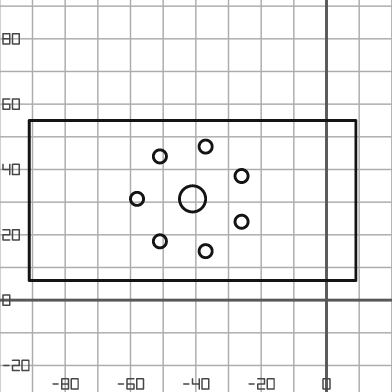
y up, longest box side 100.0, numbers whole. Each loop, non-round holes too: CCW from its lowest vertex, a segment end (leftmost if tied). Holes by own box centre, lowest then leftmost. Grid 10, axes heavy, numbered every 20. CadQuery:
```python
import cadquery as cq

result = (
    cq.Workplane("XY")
    .moveTo(-91.0, 6.0)
    .lineTo(9.0, 6.0)
    .lineTo(9.0, 55.0)
    .lineTo(-91.0, 55.0)
    .close()
    .moveTo(-37.0, 15.0)
    .circle(2.0)
    .moveTo(-51.0, 18.0)
    .circle(2.0)
    .moveTo(-26.0, 24.0)
    .circle(2.0)
    .moveTo(-58.0, 31.0)
    .circle(2.0)
    .moveTo(-41.0, 31.0)
    .circle(4.0)
    .moveTo(-26.0, 38.0)
    .circle(2.0)
    .moveTo(-51.0, 44.0)
    .circle(2.0)
    .moveTo(-37.0, 47.0)
    .circle(2.0)
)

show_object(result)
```